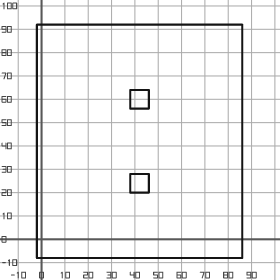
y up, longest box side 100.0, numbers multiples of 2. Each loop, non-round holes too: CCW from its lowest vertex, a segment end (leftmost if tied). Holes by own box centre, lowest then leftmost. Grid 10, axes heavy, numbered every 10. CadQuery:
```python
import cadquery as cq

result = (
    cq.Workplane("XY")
    .moveTo(-2.0, -8.0)
    .lineTo(86.0, -8.0)
    .lineTo(86.0, 92.0)
    .lineTo(-2.0, 92.0)
    .close()
    .moveTo(38.0, 20.0)
    .lineTo(46.0, 20.0)
    .lineTo(46.0, 28.0)
    .lineTo(38.0, 28.0)
    .close()
    .moveTo(38.0, 56.0)
    .lineTo(46.0, 56.0)
    .lineTo(46.0, 64.0)
    .lineTo(38.0, 64.0)
    .close()
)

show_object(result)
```